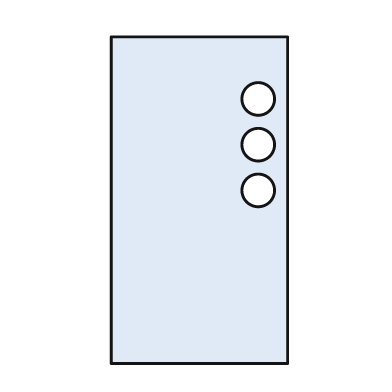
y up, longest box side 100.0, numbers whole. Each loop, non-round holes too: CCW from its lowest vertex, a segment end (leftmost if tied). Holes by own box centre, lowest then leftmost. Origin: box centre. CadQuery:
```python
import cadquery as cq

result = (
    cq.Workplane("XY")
    .moveTo(-27.0, -50.0)
    .lineTo(27.0, -50.0)
    .lineTo(27.0, 50.0)
    .lineTo(-27.0, 50.0)
    .close()
    .moveTo(18.0, 3.0)
    .circle(5.0)
    .moveTo(18.0, 17.0)
    .circle(5.0)
    .moveTo(18.0, 31.0)
    .circle(5.0)
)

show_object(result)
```